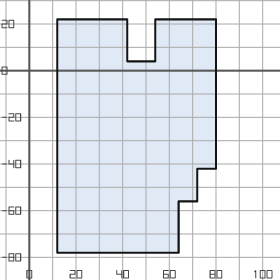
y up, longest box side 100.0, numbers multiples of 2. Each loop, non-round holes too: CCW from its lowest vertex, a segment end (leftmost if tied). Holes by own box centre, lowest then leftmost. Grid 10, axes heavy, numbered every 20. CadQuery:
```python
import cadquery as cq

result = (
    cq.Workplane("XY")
    .moveTo(12.0, -78.0)
    .lineTo(64.0, -78.0)
    .lineTo(64.0, -56.0)
    .lineTo(72.0, -56.0)
    .lineTo(72.0, -42.0)
    .lineTo(80.0, -42.0)
    .lineTo(80.0, 22.0)
    .lineTo(54.0, 22.0)
    .lineTo(54.0, 4.0)
    .lineTo(42.0, 4.0)
    .lineTo(42.0, 22.0)
    .lineTo(12.0, 22.0)
    .close()
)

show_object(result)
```